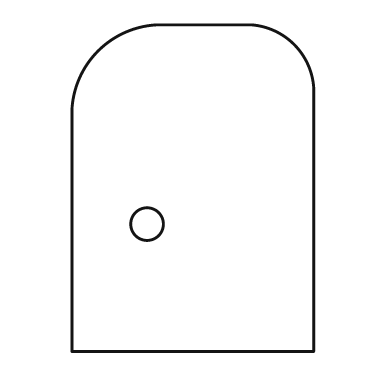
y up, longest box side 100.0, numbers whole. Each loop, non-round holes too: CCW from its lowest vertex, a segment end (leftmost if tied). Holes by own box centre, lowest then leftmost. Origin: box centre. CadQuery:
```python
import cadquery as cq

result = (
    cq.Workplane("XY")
    .moveTo(-37.0, -50.0)
    .lineTo(37.0, -50.0)
    .lineTo(37.0, 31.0)
    .threePointArc((31.0, 44.0), (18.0, 50.0))
    .lineTo(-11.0, 50.0)
    .threePointArc((-29.0, 42.0), (-37.0, 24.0))
    .close()
    .moveTo(-14.0, -11.0)
    .circle(5.0)
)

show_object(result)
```